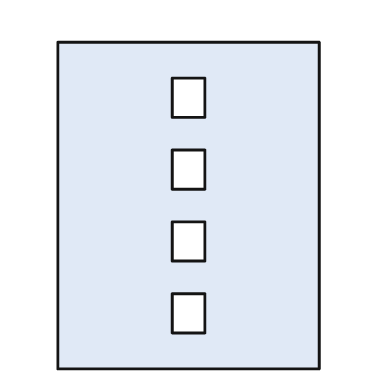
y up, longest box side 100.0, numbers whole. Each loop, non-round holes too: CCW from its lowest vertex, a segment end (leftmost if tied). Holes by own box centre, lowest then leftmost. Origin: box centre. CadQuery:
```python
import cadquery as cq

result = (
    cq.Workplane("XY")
    .moveTo(-40.0, -50.0)
    .lineTo(40.0, -50.0)
    .lineTo(40.0, 50.0)
    .lineTo(-40.0, 50.0)
    .close()
    .moveTo(-5.0, -39.0)
    .lineTo(5.0, -39.0)
    .lineTo(5.0, -27.0)
    .lineTo(-5.0, -27.0)
    .close()
    .moveTo(-5.0, -17.0)
    .lineTo(5.0, -17.0)
    .lineTo(5.0, -5.0)
    .lineTo(-5.0, -5.0)
    .close()
    .moveTo(-5.0, 5.0)
    .lineTo(5.0, 5.0)
    .lineTo(5.0, 17.0)
    .lineTo(-5.0, 17.0)
    .close()
    .moveTo(-5.0, 27.0)
    .lineTo(5.0, 27.0)
    .lineTo(5.0, 39.0)
    .lineTo(-5.0, 39.0)
    .close()
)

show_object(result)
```